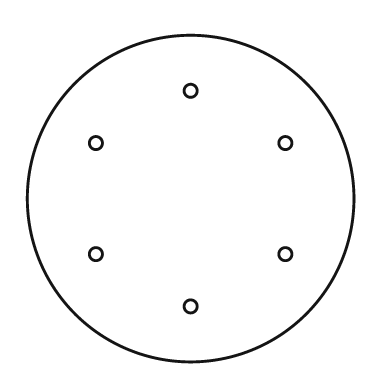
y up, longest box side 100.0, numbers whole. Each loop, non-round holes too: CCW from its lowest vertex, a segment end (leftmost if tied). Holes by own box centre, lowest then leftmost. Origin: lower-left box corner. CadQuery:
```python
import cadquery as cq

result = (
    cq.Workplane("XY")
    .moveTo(50.0, 50.0)
    .circle(50.0)
    .moveTo(50.0, 17.0)
    .circle(2.0)
    .moveTo(21.0, 33.0)
    .circle(2.0)
    .moveTo(79.0, 33.0)
    .circle(2.0)
    .moveTo(21.0, 67.0)
    .circle(2.0)
    .moveTo(79.0, 67.0)
    .circle(2.0)
    .moveTo(50.0, 83.0)
    .circle(2.0)
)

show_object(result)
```